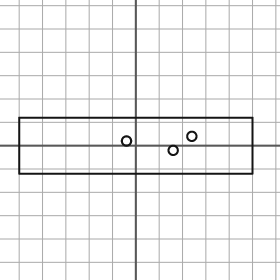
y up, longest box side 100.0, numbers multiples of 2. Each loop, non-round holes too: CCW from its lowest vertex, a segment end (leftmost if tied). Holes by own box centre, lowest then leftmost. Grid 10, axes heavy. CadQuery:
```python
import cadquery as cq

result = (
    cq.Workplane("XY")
    .moveTo(-50.0, -12.0)
    .lineTo(50.0, -12.0)
    .lineTo(50.0, 12.0)
    .lineTo(-50.0, 12.0)
    .close()
    .moveTo(16.0, -2.0)
    .circle(2.0)
    .moveTo(-4.0, 2.0)
    .circle(2.0)
    .moveTo(24.0, 4.0)
    .circle(2.0)
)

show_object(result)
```